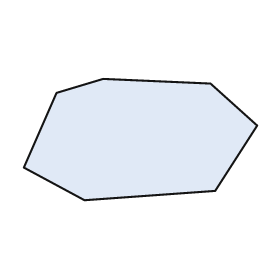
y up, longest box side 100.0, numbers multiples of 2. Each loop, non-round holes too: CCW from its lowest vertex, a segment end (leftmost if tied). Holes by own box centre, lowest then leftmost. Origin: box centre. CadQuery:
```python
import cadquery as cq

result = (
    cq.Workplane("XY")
    .moveTo(-24.0, -26.0)
    .lineTo(32.0, -22.0)
    .lineTo(50.0, 6.0)
    .lineTo(30.0, 24.0)
    .lineTo(-16.0, 26.0)
    .lineTo(-36.0, 20.0)
    .lineTo(-50.0, -12.0)
    .close()
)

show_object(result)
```